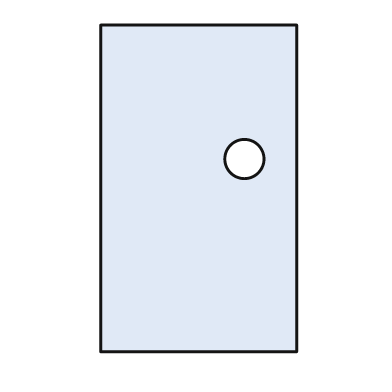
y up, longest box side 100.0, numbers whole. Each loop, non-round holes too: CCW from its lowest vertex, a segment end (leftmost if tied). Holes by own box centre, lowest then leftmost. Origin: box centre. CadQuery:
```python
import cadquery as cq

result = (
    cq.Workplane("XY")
    .moveTo(-30.0, -50.0)
    .lineTo(30.0, -50.0)
    .lineTo(30.0, 50.0)
    .lineTo(-30.0, 50.0)
    .close()
    .moveTo(14.0, 9.0)
    .circle(6.0)
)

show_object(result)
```